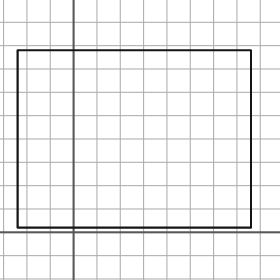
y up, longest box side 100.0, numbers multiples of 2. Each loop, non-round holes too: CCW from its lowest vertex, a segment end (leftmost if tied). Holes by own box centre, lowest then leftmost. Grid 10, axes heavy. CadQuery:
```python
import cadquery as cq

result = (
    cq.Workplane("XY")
    .moveTo(-24.0, 2.0)
    .lineTo(76.0, 2.0)
    .lineTo(76.0, 78.0)
    .lineTo(-24.0, 78.0)
    .close()
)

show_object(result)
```